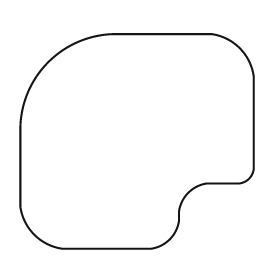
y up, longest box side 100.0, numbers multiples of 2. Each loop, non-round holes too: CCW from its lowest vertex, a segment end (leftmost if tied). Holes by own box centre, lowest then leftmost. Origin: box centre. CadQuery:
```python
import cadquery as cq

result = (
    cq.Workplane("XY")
    .moveTo(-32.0, -46.0)
    .lineTo(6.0, -46.0)
    .threePointArc((14.0, -42.0), (18.0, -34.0))
    .lineTo(18.0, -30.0)
    .threePointArc((22.0, -22.0), (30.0, -18.0))
    .lineTo(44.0, -18.0)
    .threePointArc((48.0, -16.0), (50.0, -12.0))
    .lineTo(50.0, 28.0)
    .threePointArc((44.0, 40.0), (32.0, 46.0))
    .lineTo(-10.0, 46.0)
    .threePointArc((-38.0, 34.0), (-50.0, 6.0))
    .lineTo(-50.0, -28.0)
    .threePointArc((-44.0, -40.0), (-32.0, -46.0))
    .close()
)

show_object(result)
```